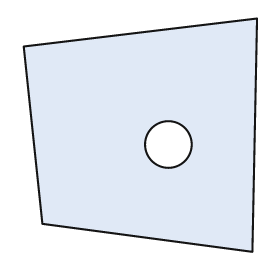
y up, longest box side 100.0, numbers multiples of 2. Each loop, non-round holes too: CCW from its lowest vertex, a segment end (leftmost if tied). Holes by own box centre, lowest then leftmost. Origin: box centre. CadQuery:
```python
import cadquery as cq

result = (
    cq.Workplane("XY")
    .moveTo(48.0, -50.0)
    .lineTo(50.0, 50.0)
    .lineTo(-50.0, 38.0)
    .lineTo(-42.0, -38.0)
    .close()
    .moveTo(12.0, -4.0)
    .circle(10.0)
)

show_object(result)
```